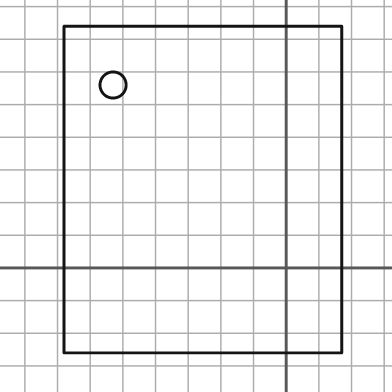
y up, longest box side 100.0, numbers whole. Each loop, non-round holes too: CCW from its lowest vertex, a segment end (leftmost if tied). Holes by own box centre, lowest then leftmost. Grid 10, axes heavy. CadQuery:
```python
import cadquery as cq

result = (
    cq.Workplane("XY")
    .moveTo(-68.0, -26.0)
    .lineTo(17.0, -26.0)
    .lineTo(17.0, 74.0)
    .lineTo(-68.0, 74.0)
    .close()
    .moveTo(-53.0, 56.0)
    .circle(4.0)
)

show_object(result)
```